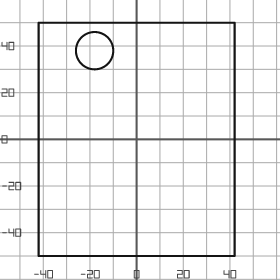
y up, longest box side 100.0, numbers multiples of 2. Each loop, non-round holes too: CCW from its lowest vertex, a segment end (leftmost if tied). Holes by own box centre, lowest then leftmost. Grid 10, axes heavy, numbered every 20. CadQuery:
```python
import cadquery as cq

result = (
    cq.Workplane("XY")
    .moveTo(-42.0, -50.0)
    .lineTo(42.0, -50.0)
    .lineTo(42.0, 50.0)
    .lineTo(-42.0, 50.0)
    .close()
    .moveTo(-18.0, 38.0)
    .circle(8.0)
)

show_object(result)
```